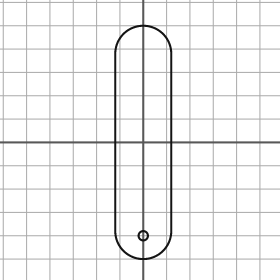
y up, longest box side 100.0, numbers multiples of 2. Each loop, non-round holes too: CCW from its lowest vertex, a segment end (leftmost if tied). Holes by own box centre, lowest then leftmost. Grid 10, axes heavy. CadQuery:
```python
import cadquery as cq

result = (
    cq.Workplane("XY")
    .moveTo(-12.0, -38.0)
    .threePointArc((0.0, -50.0), (12.0, -38.0))
    .lineTo(12.0, 38.0)
    .threePointArc((0.0, 50.0), (-12.0, 38.0))
    .close()
    .moveTo(0.0, -40.0)
    .circle(2.0)
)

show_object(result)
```